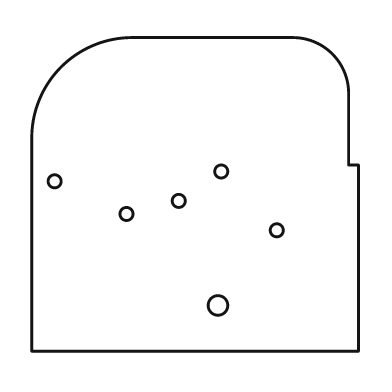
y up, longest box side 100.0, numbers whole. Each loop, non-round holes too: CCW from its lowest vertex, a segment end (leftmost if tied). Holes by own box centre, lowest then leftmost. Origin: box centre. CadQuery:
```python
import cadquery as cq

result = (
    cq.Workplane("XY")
    .moveTo(-50.0, -48.0)
    .lineTo(50.0, -48.0)
    .lineTo(50.0, 9.0)
    .lineTo(47.0, 9.0)
    .lineTo(47.0, 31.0)
    .threePointArc((42.0, 43.0), (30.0, 48.0))
    .lineTo(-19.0, 48.0)
    .threePointArc((-41.0, 39.0), (-50.0, 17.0))
    .close()
    .moveTo(7.0, -34.0)
    .circle(3.0)
    .moveTo(25.0, -11.0)
    .circle(2.0)
    .moveTo(-21.0, -6.0)
    .circle(2.0)
    .moveTo(-5.0, -2.0)
    .circle(2.0)
    .moveTo(-43.0, 4.0)
    .circle(2.0)
    .moveTo(8.0, 7.0)
    .circle(2.0)
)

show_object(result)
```